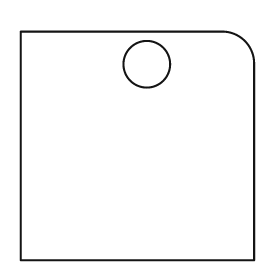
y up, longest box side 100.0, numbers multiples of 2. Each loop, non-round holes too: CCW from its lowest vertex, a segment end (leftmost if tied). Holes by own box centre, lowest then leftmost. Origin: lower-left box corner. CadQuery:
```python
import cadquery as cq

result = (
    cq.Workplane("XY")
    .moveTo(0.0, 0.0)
    .lineTo(100.0, 0.0)
    .lineTo(100.0, 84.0)
    .threePointArc((96.0, 94.0), (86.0, 98.0))
    .lineTo(0.0, 98.0)
    .close()
    .moveTo(54.0, 84.0)
    .circle(10.0)
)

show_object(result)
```